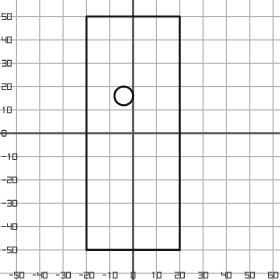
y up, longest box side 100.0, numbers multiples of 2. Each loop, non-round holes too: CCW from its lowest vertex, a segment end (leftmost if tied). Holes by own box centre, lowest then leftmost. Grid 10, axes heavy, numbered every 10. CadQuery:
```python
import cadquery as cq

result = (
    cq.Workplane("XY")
    .moveTo(-20.0, -50.0)
    .lineTo(20.0, -50.0)
    .lineTo(20.0, 50.0)
    .lineTo(-20.0, 50.0)
    .close()
    .moveTo(-4.0, 16.0)
    .circle(4.0)
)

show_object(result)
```